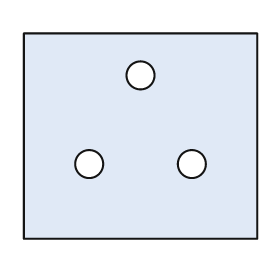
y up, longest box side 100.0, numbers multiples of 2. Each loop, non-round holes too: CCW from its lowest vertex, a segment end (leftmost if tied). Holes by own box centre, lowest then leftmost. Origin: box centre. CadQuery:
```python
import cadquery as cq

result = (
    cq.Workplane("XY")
    .moveTo(-50.0, -44.0)
    .lineTo(50.0, -44.0)
    .lineTo(50.0, 44.0)
    .lineTo(-50.0, 44.0)
    .close()
    .moveTo(-22.0, -12.0)
    .circle(6.0)
    .moveTo(22.0, -12.0)
    .circle(6.0)
    .moveTo(0.0, 26.0)
    .circle(6.0)
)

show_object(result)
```